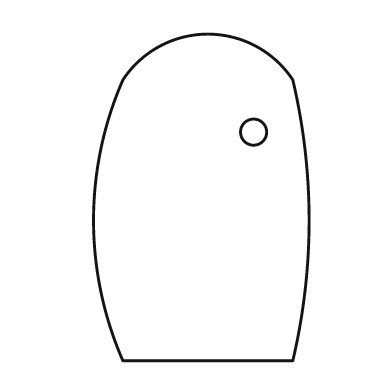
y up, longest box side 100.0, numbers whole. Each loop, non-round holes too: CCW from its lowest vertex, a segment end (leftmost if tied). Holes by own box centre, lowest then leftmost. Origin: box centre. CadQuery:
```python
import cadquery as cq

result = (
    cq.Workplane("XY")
    .moveTo(-24.0, -50.0)
    .lineTo(28.0, -50.0)
    .threePointArc((33.0, -7.0), (28.0, 36.0))
    .threePointArc((2.0, 50.0), (-24.0, 36.0))
    .threePointArc((-33.0, -7.0), (-24.0, -50.0))
    .close()
    .moveTo(16.0, 20.0)
    .circle(4.0)
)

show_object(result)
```